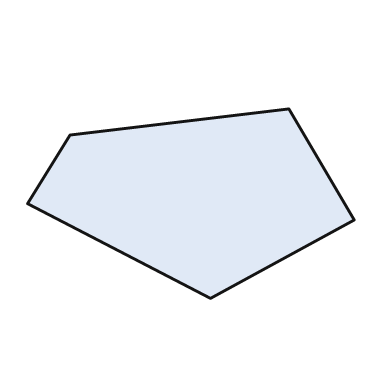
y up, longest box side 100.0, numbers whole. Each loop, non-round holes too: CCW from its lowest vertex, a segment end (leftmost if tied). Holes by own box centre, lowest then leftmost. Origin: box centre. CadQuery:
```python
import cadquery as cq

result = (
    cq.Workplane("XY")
    .moveTo(6.0, -29.0)
    .lineTo(50.0, -5.0)
    .lineTo(30.0, 29.0)
    .lineTo(-37.0, 21.0)
    .lineTo(-50.0, 0.0)
    .close()
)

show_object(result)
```